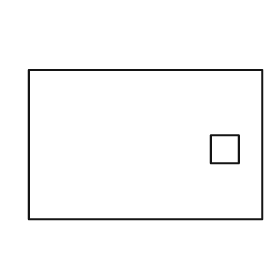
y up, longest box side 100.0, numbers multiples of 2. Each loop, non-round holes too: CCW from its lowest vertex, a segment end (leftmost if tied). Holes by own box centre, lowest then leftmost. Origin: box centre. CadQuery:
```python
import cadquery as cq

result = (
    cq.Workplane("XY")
    .moveTo(-50.0, -32.0)
    .lineTo(50.0, -32.0)
    .lineTo(50.0, 32.0)
    .lineTo(-50.0, 32.0)
    .close()
    .moveTo(28.0, -8.0)
    .lineTo(40.0, -8.0)
    .lineTo(40.0, 4.0)
    .lineTo(28.0, 4.0)
    .close()
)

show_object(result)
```